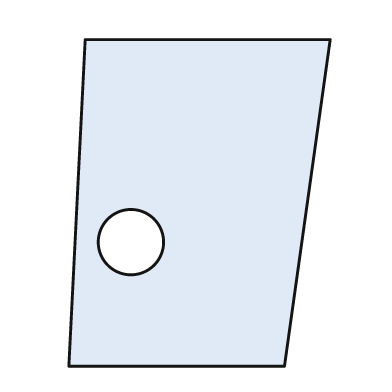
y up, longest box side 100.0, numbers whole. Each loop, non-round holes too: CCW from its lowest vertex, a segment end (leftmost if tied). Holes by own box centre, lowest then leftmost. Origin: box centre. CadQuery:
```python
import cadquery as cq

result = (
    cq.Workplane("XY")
    .moveTo(-40.0, -50.0)
    .lineTo(26.0, -50.0)
    .lineTo(40.0, 50.0)
    .lineTo(-35.0, 50.0)
    .close()
    .moveTo(-21.0, -12.0)
    .circle(10.0)
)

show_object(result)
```